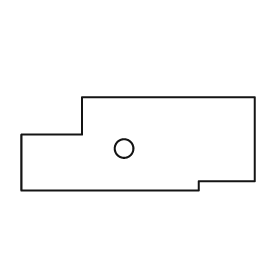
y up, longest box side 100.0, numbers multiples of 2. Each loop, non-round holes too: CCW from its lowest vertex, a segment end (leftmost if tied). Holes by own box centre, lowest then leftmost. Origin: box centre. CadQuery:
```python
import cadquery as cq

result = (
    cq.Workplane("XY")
    .moveTo(-50.0, -20.0)
    .lineTo(26.0, -20.0)
    .lineTo(26.0, -16.0)
    .lineTo(50.0, -16.0)
    .lineTo(50.0, 20.0)
    .lineTo(-24.0, 20.0)
    .lineTo(-24.0, 4.0)
    .lineTo(-50.0, 4.0)
    .close()
    .moveTo(-6.0, -2.0)
    .circle(4.0)
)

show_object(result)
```